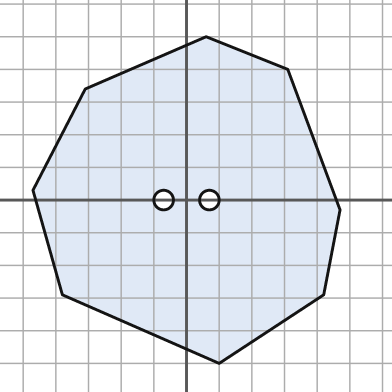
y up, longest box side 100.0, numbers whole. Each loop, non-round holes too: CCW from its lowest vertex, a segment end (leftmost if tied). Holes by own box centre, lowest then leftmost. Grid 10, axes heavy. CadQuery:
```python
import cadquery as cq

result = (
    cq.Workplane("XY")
    .moveTo(10.0, -50.0)
    .lineTo(42.0, -29.0)
    .lineTo(47.0, -3.0)
    .lineTo(31.0, 40.0)
    .lineTo(6.0, 50.0)
    .lineTo(-31.0, 34.0)
    .lineTo(-47.0, 3.0)
    .lineTo(-38.0, -29.0)
    .close()
    .moveTo(-7.0, 0.0)
    .circle(3.0)
    .moveTo(7.0, 0.0)
    .circle(3.0)
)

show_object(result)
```